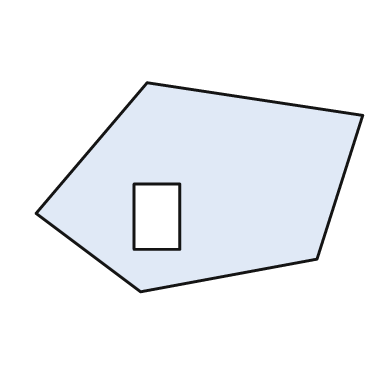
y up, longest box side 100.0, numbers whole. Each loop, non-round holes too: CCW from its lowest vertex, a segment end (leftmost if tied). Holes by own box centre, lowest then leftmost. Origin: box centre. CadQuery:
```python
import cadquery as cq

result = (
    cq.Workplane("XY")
    .moveTo(-18.0, -32.0)
    .lineTo(36.0, -22.0)
    .lineTo(50.0, 22.0)
    .lineTo(-16.0, 32.0)
    .lineTo(-50.0, -8.0)
    .close()
    .moveTo(-20.0, -19.0)
    .lineTo(-6.0, -19.0)
    .lineTo(-6.0, 1.0)
    .lineTo(-20.0, 1.0)
    .close()
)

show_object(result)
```